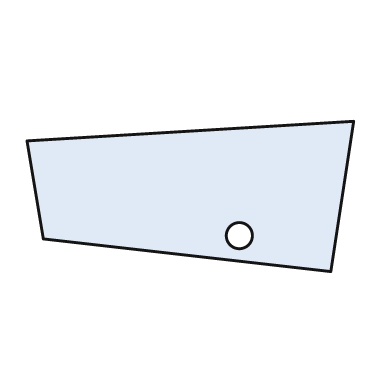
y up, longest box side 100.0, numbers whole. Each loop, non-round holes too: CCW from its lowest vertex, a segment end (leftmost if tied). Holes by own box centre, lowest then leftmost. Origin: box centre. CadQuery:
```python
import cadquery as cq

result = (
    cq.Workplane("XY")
    .moveTo(43.0, -23.0)
    .lineTo(50.0, 23.0)
    .lineTo(-50.0, 17.0)
    .lineTo(-45.0, -13.0)
    .close()
    .moveTo(15.0, -12.0)
    .circle(4.0)
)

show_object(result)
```